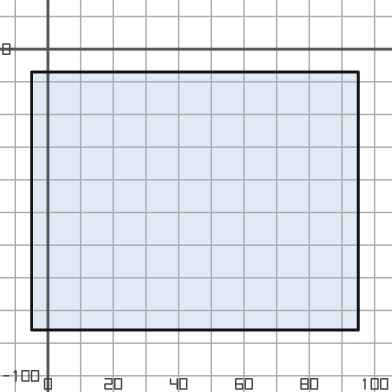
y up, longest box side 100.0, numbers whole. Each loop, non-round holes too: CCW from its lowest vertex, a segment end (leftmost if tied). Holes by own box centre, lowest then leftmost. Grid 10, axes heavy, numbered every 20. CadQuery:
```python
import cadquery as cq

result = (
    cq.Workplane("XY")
    .moveTo(-5.0, -86.0)
    .lineTo(95.0, -86.0)
    .lineTo(95.0, -7.0)
    .lineTo(-5.0, -7.0)
    .close()
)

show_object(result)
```